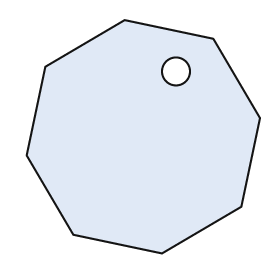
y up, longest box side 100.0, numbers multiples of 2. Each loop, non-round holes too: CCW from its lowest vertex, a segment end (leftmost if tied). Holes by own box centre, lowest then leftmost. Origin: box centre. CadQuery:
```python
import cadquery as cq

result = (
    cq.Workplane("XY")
    .moveTo(8.0, -50.0)
    .lineTo(42.0, -30.0)
    .lineTo(50.0, 8.0)
    .lineTo(30.0, 42.0)
    .lineTo(-8.0, 50.0)
    .lineTo(-42.0, 30.0)
    .lineTo(-50.0, -8.0)
    .lineTo(-30.0, -42.0)
    .close()
    .moveTo(14.0, 28.0)
    .circle(6.0)
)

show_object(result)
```